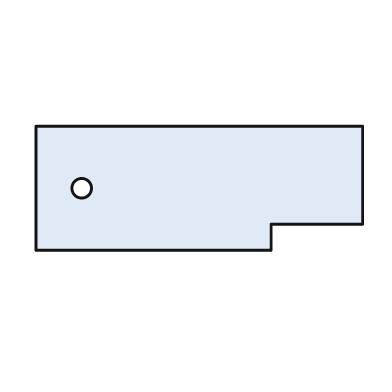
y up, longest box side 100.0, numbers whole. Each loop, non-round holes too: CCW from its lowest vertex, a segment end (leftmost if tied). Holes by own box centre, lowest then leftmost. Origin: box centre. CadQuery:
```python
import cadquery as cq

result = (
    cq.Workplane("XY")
    .moveTo(-50.0, -19.0)
    .lineTo(22.0, -19.0)
    .lineTo(22.0, -11.0)
    .lineTo(50.0, -11.0)
    .lineTo(50.0, 19.0)
    .lineTo(-50.0, 19.0)
    .close()
    .moveTo(-36.0, 0.0)
    .circle(3.0)
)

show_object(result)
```